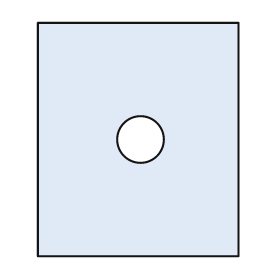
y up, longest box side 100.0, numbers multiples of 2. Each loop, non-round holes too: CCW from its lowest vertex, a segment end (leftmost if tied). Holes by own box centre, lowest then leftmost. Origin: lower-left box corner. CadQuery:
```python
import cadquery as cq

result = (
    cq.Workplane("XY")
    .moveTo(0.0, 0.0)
    .lineTo(86.0, 0.0)
    .lineTo(86.0, 100.0)
    .lineTo(0.0, 100.0)
    .close()
    .moveTo(44.0, 50.0)
    .circle(10.0)
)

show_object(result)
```